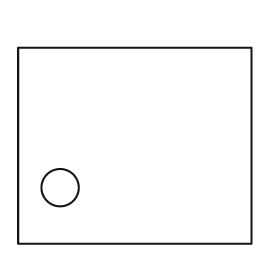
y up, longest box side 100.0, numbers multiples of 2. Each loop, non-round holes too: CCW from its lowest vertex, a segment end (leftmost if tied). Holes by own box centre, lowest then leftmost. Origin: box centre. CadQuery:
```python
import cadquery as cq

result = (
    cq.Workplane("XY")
    .moveTo(-50.0, -42.0)
    .lineTo(50.0, -42.0)
    .lineTo(50.0, 42.0)
    .lineTo(-50.0, 42.0)
    .close()
    .moveTo(-32.0, -18.0)
    .circle(8.0)
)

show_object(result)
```